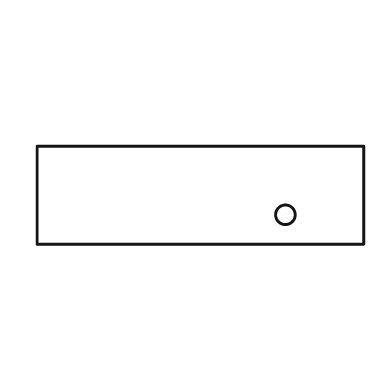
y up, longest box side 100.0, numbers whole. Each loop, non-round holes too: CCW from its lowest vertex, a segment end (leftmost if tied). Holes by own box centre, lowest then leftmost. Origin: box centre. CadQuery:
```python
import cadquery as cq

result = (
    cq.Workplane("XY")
    .moveTo(-50.0, -15.0)
    .lineTo(50.0, -15.0)
    .lineTo(50.0, 15.0)
    .lineTo(-50.0, 15.0)
    .close()
    .moveTo(26.0, -6.0)
    .circle(3.0)
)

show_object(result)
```